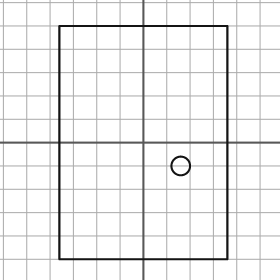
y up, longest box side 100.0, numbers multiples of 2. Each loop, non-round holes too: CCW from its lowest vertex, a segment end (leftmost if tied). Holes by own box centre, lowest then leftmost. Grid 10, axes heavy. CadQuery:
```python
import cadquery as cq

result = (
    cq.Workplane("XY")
    .moveTo(-36.0, -50.0)
    .lineTo(36.0, -50.0)
    .lineTo(36.0, 50.0)
    .lineTo(-36.0, 50.0)
    .close()
    .moveTo(16.0, -10.0)
    .circle(4.0)
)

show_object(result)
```